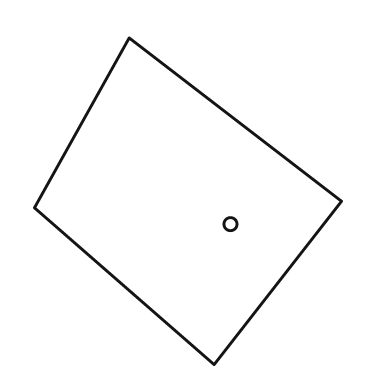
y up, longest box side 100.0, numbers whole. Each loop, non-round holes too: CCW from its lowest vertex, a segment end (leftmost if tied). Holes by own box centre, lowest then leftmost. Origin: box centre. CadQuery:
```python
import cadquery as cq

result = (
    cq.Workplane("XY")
    .moveTo(8.0, -50.0)
    .lineTo(47.0, 0.0)
    .lineTo(-18.0, 50.0)
    .lineTo(-47.0, -2.0)
    .close()
    .moveTo(13.0, -7.0)
    .circle(2.0)
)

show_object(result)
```